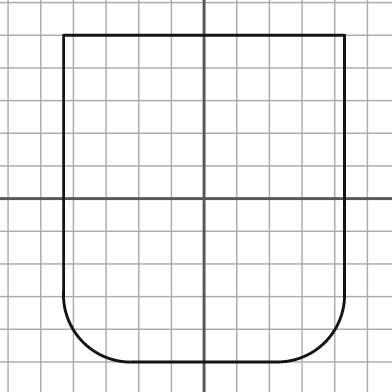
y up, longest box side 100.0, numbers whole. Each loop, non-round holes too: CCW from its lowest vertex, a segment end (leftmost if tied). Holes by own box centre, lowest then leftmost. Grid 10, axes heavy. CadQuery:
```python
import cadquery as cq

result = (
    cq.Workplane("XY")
    .moveTo(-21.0, -50.0)
    .lineTo(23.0, -50.0)
    .threePointArc((37.0, -44.0), (43.0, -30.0))
    .lineTo(43.0, 50.0)
    .lineTo(-43.0, 50.0)
    .lineTo(-43.0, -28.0)
    .threePointArc((-37.0, -44.0), (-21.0, -50.0))
    .close()
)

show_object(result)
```